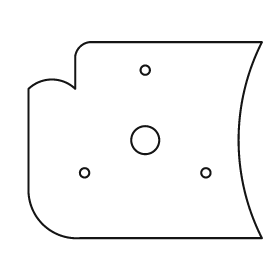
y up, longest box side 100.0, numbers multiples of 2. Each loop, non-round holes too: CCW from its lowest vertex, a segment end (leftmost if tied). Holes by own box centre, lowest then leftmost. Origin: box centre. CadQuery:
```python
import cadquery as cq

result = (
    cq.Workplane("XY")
    .moveTo(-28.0, -42.0)
    .lineTo(50.0, -42.0)
    .threePointArc((40.0, 0.0), (50.0, 42.0))
    .lineTo(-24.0, 42.0)
    .threePointArc((-28.0, 40.0), (-30.0, 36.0))
    .lineTo(-30.0, 22.0)
    .threePointArc((-40.0, 26.0), (-50.0, 22.0))
    .lineTo(-50.0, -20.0)
    .threePointArc((-44.0, -36.0), (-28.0, -42.0))
    .close()
    .moveTo(-26.0, -14.0)
    .circle(2.0)
    .moveTo(26.0, -14.0)
    .circle(2.0)
    .moveTo(0.0, 0.0)
    .circle(6.0)
    .moveTo(0.0, 30.0)
    .circle(2.0)
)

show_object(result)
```